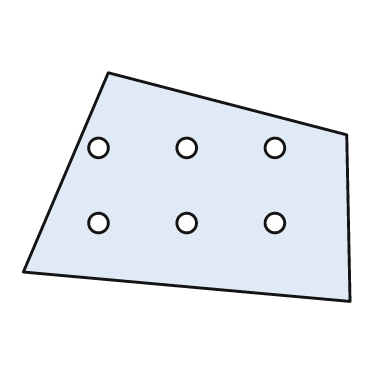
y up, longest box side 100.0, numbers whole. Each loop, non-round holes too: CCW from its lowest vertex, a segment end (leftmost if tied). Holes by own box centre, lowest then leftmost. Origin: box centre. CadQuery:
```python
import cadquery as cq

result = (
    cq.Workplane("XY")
    .moveTo(50.0, -35.0)
    .lineTo(49.0, 16.0)
    .lineTo(-24.0, 35.0)
    .lineTo(-50.0, -26.0)
    .close()
    .moveTo(-27.0, -11.0)
    .circle(3.0)
    .moveTo(0.0, -11.0)
    .circle(3.0)
    .moveTo(27.0, -11.0)
    .circle(3.0)
    .moveTo(-27.0, 12.0)
    .circle(3.0)
    .moveTo(0.0, 12.0)
    .circle(3.0)
    .moveTo(27.0, 12.0)
    .circle(3.0)
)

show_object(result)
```